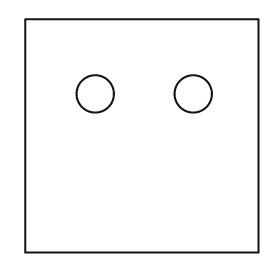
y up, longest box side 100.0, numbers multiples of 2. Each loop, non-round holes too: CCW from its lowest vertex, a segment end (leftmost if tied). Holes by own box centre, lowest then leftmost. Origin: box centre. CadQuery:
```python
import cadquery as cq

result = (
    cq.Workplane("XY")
    .moveTo(-50.0, -50.0)
    .lineTo(50.0, -50.0)
    .lineTo(50.0, 50.0)
    .lineTo(-50.0, 50.0)
    .close()
    .moveTo(-20.0, 18.0)
    .circle(8.0)
    .moveTo(22.0, 18.0)
    .circle(8.0)
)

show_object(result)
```